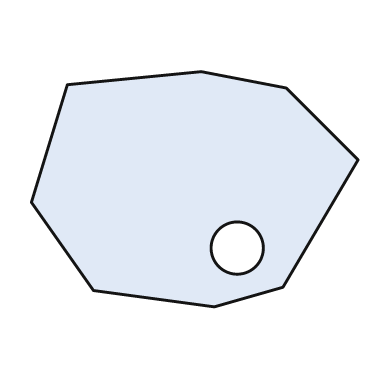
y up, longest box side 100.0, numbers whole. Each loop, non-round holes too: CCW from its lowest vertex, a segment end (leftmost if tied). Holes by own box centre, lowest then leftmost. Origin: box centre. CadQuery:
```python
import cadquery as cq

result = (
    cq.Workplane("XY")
    .moveTo(6.0, -36.0)
    .lineTo(27.0, -30.0)
    .lineTo(50.0, 9.0)
    .lineTo(28.0, 31.0)
    .lineTo(2.0, 36.0)
    .lineTo(-39.0, 32.0)
    .lineTo(-50.0, -4.0)
    .lineTo(-31.0, -31.0)
    .close()
    .moveTo(13.0, -18.0)
    .circle(8.0)
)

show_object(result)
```